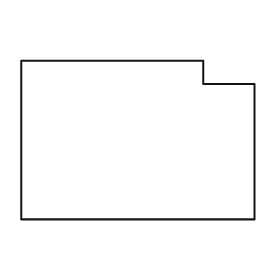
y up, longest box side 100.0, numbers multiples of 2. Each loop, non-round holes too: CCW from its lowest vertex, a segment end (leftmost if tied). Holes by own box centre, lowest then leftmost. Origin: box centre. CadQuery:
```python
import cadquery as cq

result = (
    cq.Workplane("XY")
    .moveTo(-50.0, -34.0)
    .lineTo(50.0, -34.0)
    .lineTo(50.0, 24.0)
    .lineTo(28.0, 24.0)
    .lineTo(28.0, 34.0)
    .lineTo(-50.0, 34.0)
    .close()
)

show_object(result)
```